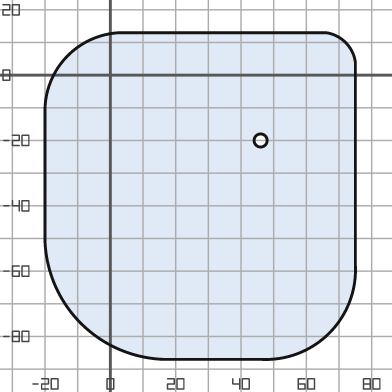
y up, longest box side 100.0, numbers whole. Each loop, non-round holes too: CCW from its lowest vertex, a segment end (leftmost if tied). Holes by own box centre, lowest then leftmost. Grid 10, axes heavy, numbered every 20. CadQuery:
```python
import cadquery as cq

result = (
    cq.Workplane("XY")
    .moveTo(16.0, -87.0)
    .lineTo(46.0, -87.0)
    .threePointArc((67.0, -79.0), (75.0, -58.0))
    .lineTo(75.0, 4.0)
    .threePointArc((72.0, 10.0), (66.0, 13.0))
    .lineTo(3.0, 13.0)
    .threePointArc((-13.0, 6.0), (-20.0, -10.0))
    .lineTo(-20.0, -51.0)
    .threePointArc((-9.0, -76.0), (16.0, -87.0))
    .close()
    .moveTo(46.0, -20.0)
    .circle(2.0)
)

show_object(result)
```